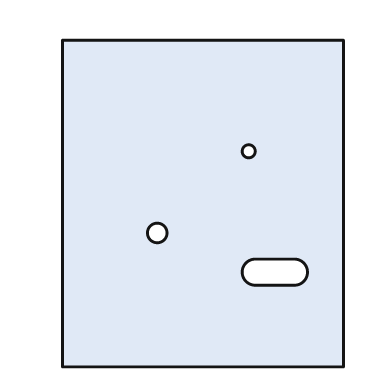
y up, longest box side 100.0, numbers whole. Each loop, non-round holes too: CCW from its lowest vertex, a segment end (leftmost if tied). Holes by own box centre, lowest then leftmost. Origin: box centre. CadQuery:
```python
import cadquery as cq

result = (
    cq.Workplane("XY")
    .moveTo(-43.0, -50.0)
    .lineTo(43.0, -50.0)
    .lineTo(43.0, 50.0)
    .lineTo(-43.0, 50.0)
    .close()
    .moveTo(16.0, -25.0)
    .lineTo(28.0, -25.0)
    .threePointArc((32.0, -21.0), (28.0, -17.0))
    .lineTo(16.0, -17.0)
    .threePointArc((12.0, -21.0), (16.0, -25.0))
    .close()
    .moveTo(-14.0, -9.0)
    .circle(3.0)
    .moveTo(14.0, 16.0)
    .circle(2.0)
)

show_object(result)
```